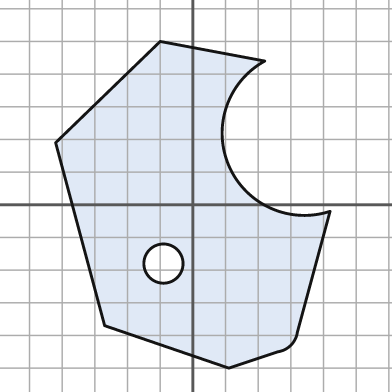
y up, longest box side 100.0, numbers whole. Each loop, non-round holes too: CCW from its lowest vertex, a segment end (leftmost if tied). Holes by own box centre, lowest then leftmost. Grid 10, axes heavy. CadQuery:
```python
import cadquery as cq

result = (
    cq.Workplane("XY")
    .moveTo(11.0, -50.0)
    .lineTo(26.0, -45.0)
    .threePointArc((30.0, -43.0), (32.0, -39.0))
    .lineTo(42.0, -2.0)
    .threePointArc((11.0, 12.0), (22.0, 44.0))
    .lineTo(-10.0, 50.0)
    .lineTo(-42.0, 19.0)
    .lineTo(-27.0, -37.0)
    .close()
    .moveTo(-9.0, -18.0)
    .circle(6.0)
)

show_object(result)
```